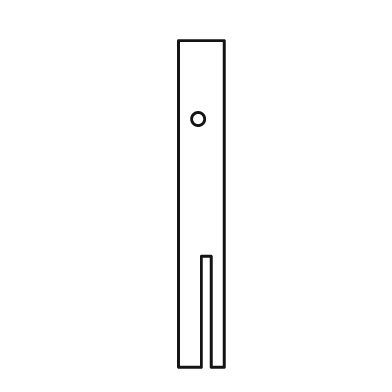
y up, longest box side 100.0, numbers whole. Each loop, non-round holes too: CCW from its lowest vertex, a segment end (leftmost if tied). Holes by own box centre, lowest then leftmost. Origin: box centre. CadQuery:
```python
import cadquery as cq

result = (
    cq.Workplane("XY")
    .moveTo(-7.0, -50.0)
    .lineTo(0.0, -50.0)
    .lineTo(0.0, -16.0)
    .lineTo(3.0, -16.0)
    .lineTo(3.0, -50.0)
    .lineTo(7.0, -50.0)
    .lineTo(7.0, 50.0)
    .lineTo(-7.0, 50.0)
    .close()
    .moveTo(-1.0, 26.0)
    .circle(2.0)
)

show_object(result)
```